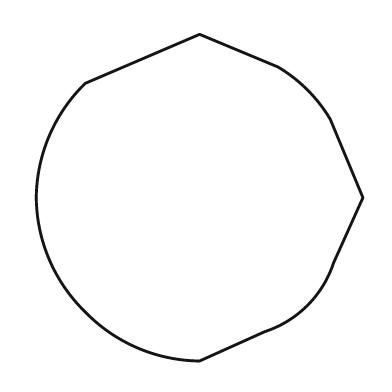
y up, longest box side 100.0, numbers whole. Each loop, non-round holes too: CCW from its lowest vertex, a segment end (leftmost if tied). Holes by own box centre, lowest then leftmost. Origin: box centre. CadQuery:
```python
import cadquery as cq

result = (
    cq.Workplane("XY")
    .moveTo(0.0, -50.0)
    .lineTo(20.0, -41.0)
    .threePointArc((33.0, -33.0), (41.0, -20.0))
    .lineTo(50.0, 0.0)
    .lineTo(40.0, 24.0)
    .threePointArc((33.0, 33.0), (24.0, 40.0))
    .lineTo(0.0, 50.0)
    .lineTo(-35.0, 35.0)
    .threePointArc((-46.0, 19.0), (-50.0, 0.0))
    .threePointArc((-46.0, -19.0), (-35.0, -35.0))
    .threePointArc((-19.0, -46.0), (0.0, -50.0))
    .close()
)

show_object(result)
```